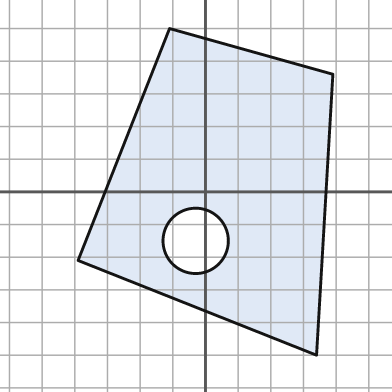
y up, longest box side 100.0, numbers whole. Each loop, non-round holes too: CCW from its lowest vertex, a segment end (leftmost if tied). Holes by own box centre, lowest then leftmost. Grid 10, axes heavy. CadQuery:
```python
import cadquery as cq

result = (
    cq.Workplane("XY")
    .moveTo(34.0, -50.0)
    .lineTo(39.0, 36.0)
    .lineTo(-11.0, 50.0)
    .lineTo(-39.0, -21.0)
    .close()
    .moveTo(-3.0, -15.0)
    .circle(10.0)
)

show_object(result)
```